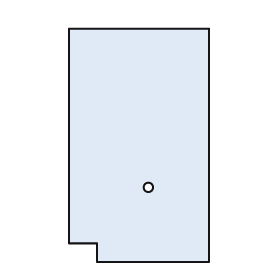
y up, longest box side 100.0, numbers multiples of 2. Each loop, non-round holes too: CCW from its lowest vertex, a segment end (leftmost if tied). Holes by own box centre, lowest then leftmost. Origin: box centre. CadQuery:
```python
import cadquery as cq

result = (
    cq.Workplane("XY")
    .moveTo(-18.0, -50.0)
    .lineTo(30.0, -50.0)
    .lineTo(30.0, 50.0)
    .lineTo(-30.0, 50.0)
    .lineTo(-30.0, -42.0)
    .lineTo(-18.0, -42.0)
    .close()
    .moveTo(4.0, -18.0)
    .circle(2.0)
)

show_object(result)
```